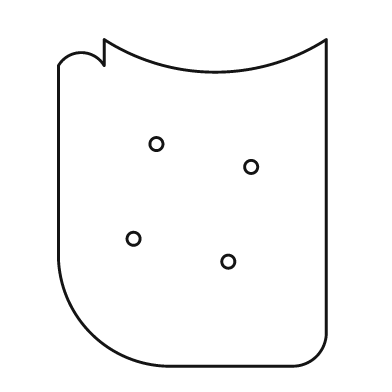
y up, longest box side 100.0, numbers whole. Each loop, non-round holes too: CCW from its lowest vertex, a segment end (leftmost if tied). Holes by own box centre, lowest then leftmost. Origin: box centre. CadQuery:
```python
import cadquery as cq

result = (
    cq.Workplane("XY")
    .moveTo(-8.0, -50.0)
    .lineTo(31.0, -50.0)
    .threePointArc((38.0, -47.0), (41.0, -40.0))
    .lineTo(41.0, 50.0)
    .threePointArc((7.0, 40.0), (-27.0, 50.0))
    .lineTo(-27.0, 42.0)
    .threePointArc((-34.0, 46.0), (-41.0, 42.0))
    .lineTo(-41.0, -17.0)
    .threePointArc((-31.0, -40.0), (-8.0, -50.0))
    .close()
    .moveTo(11.0, -18.0)
    .circle(2.0)
    .moveTo(-18.0, -11.0)
    .circle(2.0)
    .moveTo(18.0, 11.0)
    .circle(2.0)
    .moveTo(-11.0, 18.0)
    .circle(2.0)
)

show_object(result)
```